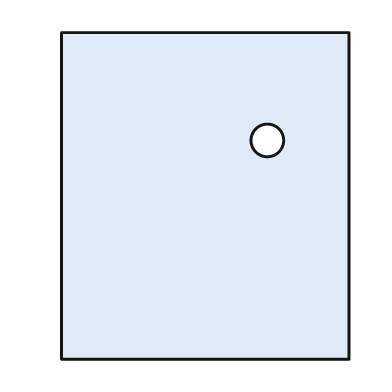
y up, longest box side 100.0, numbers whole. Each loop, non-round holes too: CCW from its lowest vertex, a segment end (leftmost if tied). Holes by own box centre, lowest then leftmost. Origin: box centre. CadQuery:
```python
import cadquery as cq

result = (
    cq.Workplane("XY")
    .moveTo(-44.0, -50.0)
    .lineTo(44.0, -50.0)
    .lineTo(44.0, 50.0)
    .lineTo(-44.0, 50.0)
    .close()
    .moveTo(19.0, 17.0)
    .circle(5.0)
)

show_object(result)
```